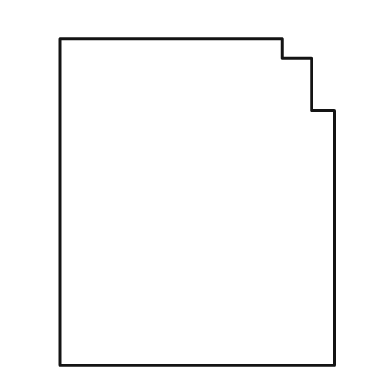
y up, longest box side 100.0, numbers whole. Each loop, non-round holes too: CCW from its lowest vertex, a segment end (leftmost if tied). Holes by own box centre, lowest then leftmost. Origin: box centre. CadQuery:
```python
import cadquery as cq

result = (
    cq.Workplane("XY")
    .moveTo(-42.0, -50.0)
    .lineTo(42.0, -50.0)
    .lineTo(42.0, 28.0)
    .lineTo(35.0, 28.0)
    .lineTo(35.0, 44.0)
    .lineTo(26.0, 44.0)
    .lineTo(26.0, 50.0)
    .lineTo(-42.0, 50.0)
    .close()
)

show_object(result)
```